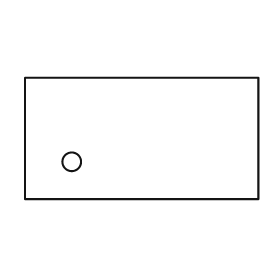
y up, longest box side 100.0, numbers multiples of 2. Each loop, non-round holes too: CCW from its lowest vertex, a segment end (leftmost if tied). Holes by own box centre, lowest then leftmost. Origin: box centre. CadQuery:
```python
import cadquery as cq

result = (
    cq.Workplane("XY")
    .moveTo(-50.0, -26.0)
    .lineTo(50.0, -26.0)
    .lineTo(50.0, 26.0)
    .lineTo(-50.0, 26.0)
    .close()
    .moveTo(-30.0, -10.0)
    .circle(4.0)
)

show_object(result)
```